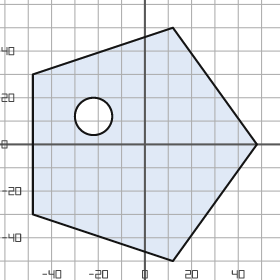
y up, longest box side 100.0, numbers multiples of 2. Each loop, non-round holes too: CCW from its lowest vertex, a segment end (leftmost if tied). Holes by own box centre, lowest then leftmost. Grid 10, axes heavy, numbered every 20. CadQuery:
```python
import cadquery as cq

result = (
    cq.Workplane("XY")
    .moveTo(12.0, -50.0)
    .lineTo(48.0, 0.0)
    .lineTo(12.0, 50.0)
    .lineTo(-48.0, 30.0)
    .lineTo(-48.0, -30.0)
    .close()
    .moveTo(-22.0, 12.0)
    .circle(8.0)
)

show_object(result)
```